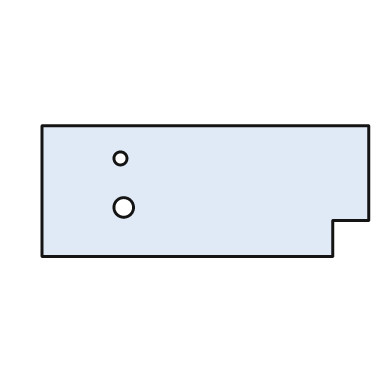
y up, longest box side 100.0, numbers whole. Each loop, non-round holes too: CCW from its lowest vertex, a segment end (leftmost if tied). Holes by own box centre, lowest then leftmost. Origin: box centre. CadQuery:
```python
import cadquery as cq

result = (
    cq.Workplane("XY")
    .moveTo(-50.0, -20.0)
    .lineTo(39.0, -20.0)
    .lineTo(39.0, -9.0)
    .lineTo(50.0, -9.0)
    .lineTo(50.0, 20.0)
    .lineTo(-50.0, 20.0)
    .close()
    .moveTo(-25.0, -5.0)
    .circle(3.0)
    .moveTo(-26.0, 10.0)
    .circle(2.0)
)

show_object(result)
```